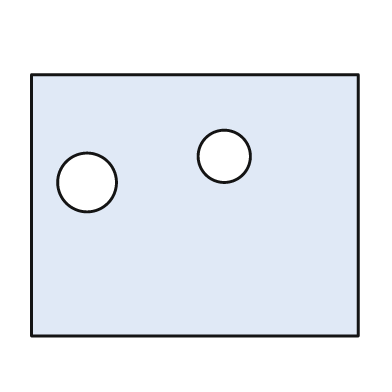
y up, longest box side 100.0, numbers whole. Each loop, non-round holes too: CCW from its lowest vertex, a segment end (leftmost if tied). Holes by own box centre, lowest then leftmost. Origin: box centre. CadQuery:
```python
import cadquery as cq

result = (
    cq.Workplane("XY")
    .moveTo(-50.0, -40.0)
    .lineTo(50.0, -40.0)
    .lineTo(50.0, 40.0)
    .lineTo(-50.0, 40.0)
    .close()
    .moveTo(-33.0, 7.0)
    .circle(9.0)
    .moveTo(9.0, 15.0)
    .circle(8.0)
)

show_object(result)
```